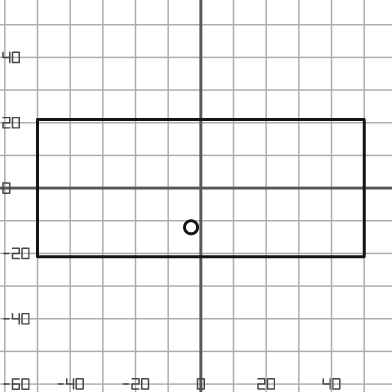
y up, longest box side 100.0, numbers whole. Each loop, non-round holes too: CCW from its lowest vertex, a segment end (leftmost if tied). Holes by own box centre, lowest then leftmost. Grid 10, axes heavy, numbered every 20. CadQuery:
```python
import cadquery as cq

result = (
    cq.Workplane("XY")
    .moveTo(-50.0, -21.0)
    .lineTo(50.0, -21.0)
    .lineTo(50.0, 21.0)
    .lineTo(-50.0, 21.0)
    .close()
    .moveTo(-3.0, -12.0)
    .circle(2.0)
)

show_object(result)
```